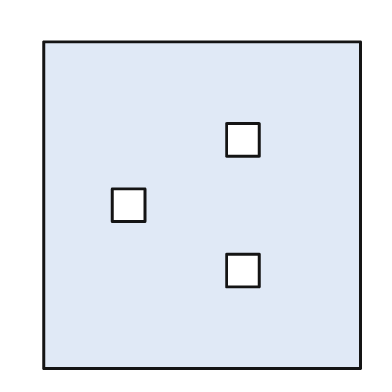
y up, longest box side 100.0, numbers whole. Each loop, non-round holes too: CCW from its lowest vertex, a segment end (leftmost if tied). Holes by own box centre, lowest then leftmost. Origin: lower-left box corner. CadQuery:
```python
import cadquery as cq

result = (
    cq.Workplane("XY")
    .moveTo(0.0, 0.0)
    .lineTo(97.0, 0.0)
    .lineTo(97.0, 100.0)
    .lineTo(0.0, 100.0)
    .close()
    .moveTo(56.0, 25.0)
    .lineTo(66.0, 25.0)
    .lineTo(66.0, 35.0)
    .lineTo(56.0, 35.0)
    .close()
    .moveTo(21.0, 45.0)
    .lineTo(31.0, 45.0)
    .lineTo(31.0, 55.0)
    .lineTo(21.0, 55.0)
    .close()
    .moveTo(56.0, 65.0)
    .lineTo(66.0, 65.0)
    .lineTo(66.0, 75.0)
    .lineTo(56.0, 75.0)
    .close()
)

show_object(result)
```